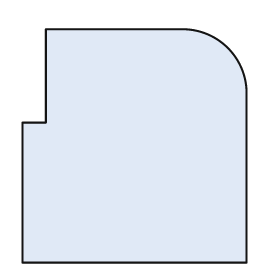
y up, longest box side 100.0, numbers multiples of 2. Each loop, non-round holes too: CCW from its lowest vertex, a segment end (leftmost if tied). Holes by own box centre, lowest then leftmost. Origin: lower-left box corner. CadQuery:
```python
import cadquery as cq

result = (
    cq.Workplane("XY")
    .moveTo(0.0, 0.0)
    .lineTo(96.0, 0.0)
    .lineTo(96.0, 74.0)
    .threePointArc((88.0, 92.0), (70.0, 100.0))
    .lineTo(10.0, 100.0)
    .lineTo(10.0, 60.0)
    .lineTo(0.0, 60.0)
    .close()
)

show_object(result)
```